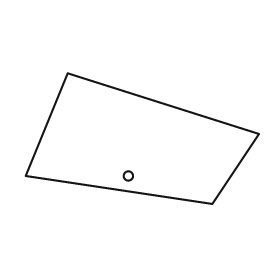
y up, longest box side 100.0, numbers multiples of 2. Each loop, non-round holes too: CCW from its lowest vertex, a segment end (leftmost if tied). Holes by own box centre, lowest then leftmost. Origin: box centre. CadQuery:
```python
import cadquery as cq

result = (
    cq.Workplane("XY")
    .moveTo(30.0, -28.0)
    .lineTo(50.0, 2.0)
    .lineTo(-32.0, 28.0)
    .lineTo(-50.0, -16.0)
    .close()
    .moveTo(-6.0, -16.0)
    .circle(2.0)
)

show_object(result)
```